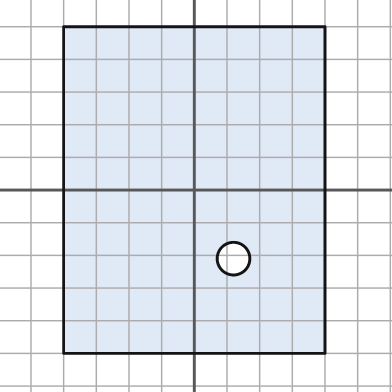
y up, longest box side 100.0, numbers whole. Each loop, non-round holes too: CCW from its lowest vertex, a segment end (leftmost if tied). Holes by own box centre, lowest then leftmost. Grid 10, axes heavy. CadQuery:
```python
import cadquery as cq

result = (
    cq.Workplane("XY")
    .moveTo(-40.0, -50.0)
    .lineTo(40.0, -50.0)
    .lineTo(40.0, 50.0)
    .lineTo(-40.0, 50.0)
    .close()
    .moveTo(12.0, -21.0)
    .circle(5.0)
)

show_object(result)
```